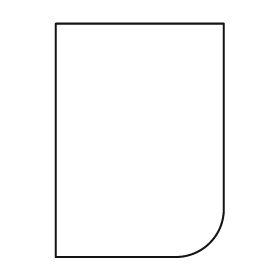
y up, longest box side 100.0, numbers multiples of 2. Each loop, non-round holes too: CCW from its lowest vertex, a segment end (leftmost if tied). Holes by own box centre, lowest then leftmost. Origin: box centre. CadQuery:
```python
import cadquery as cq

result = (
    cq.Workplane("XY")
    .moveTo(-36.0, -50.0)
    .lineTo(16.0, -50.0)
    .threePointArc((30.0, -44.0), (36.0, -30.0))
    .lineTo(36.0, 50.0)
    .lineTo(-36.0, 50.0)
    .close()
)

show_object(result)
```